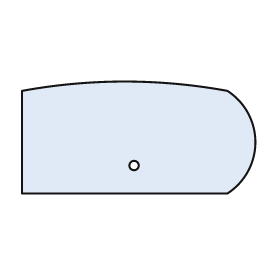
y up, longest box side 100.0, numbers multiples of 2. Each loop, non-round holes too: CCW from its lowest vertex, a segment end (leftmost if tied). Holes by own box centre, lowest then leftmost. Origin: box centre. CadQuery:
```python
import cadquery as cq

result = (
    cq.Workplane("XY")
    .moveTo(-50.0, -24.0)
    .lineTo(38.0, -24.0)
    .threePointArc((50.0, -2.0), (38.0, 20.0))
    .threePointArc((-6.0, 24.0), (-50.0, 20.0))
    .close()
    .moveTo(-2.0, -12.0)
    .circle(2.0)
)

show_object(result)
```